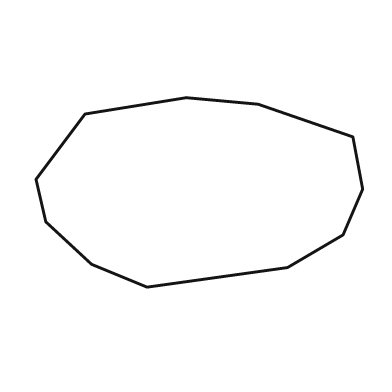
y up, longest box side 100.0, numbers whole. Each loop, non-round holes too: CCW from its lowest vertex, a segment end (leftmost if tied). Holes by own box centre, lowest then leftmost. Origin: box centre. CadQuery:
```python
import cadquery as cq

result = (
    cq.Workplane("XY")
    .moveTo(-16.0, -29.0)
    .lineTo(27.0, -23.0)
    .lineTo(44.0, -13.0)
    .lineTo(50.0, 1.0)
    .lineTo(47.0, 17.0)
    .lineTo(18.0, 27.0)
    .lineTo(-4.0, 29.0)
    .lineTo(-35.0, 24.0)
    .lineTo(-50.0, 4.0)
    .lineTo(-47.0, -9.0)
    .lineTo(-33.0, -22.0)
    .close()
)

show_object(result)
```